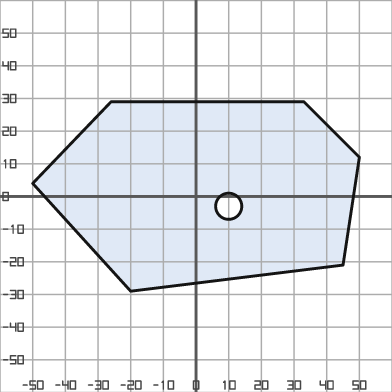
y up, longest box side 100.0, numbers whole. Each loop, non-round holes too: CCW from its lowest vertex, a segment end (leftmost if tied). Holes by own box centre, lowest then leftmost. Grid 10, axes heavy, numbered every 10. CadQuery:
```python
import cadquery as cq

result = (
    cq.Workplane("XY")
    .moveTo(-20.0, -29.0)
    .lineTo(45.0, -21.0)
    .lineTo(50.0, 12.0)
    .lineTo(33.0, 29.0)
    .lineTo(-26.0, 29.0)
    .lineTo(-50.0, 4.0)
    .close()
    .moveTo(10.0, -3.0)
    .circle(4.0)
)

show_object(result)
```